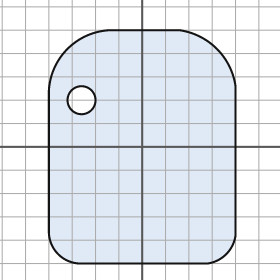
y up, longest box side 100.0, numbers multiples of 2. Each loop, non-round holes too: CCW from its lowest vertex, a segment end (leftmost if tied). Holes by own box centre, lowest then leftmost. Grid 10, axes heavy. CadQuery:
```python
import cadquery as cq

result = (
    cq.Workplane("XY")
    .moveTo(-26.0, -50.0)
    .lineTo(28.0, -50.0)
    .threePointArc((36.0, -46.0), (40.0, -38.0))
    .lineTo(40.0, 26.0)
    .threePointArc((32.0, 42.0), (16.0, 50.0))
    .lineTo(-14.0, 50.0)
    .threePointArc((-32.0, 42.0), (-40.0, 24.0))
    .lineTo(-40.0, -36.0)
    .threePointArc((-36.0, -46.0), (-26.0, -50.0))
    .close()
    .moveTo(-26.0, 20.0)
    .circle(6.0)
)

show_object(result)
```